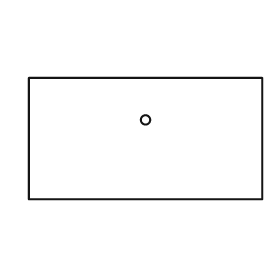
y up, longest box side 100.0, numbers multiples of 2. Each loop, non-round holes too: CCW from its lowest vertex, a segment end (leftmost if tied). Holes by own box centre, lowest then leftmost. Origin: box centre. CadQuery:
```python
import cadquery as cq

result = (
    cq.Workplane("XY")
    .moveTo(-50.0, -26.0)
    .lineTo(50.0, -26.0)
    .lineTo(50.0, 26.0)
    .lineTo(-50.0, 26.0)
    .close()
    .moveTo(0.0, 8.0)
    .circle(2.0)
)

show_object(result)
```